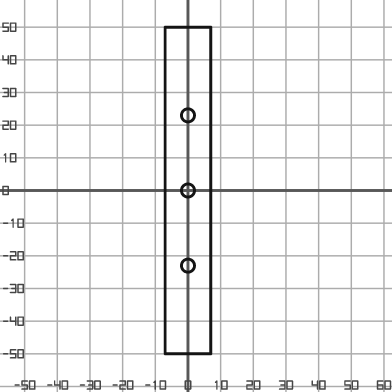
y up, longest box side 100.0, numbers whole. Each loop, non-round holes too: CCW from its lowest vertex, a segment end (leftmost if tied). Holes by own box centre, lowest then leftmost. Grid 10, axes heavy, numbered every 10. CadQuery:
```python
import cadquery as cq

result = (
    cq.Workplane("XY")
    .moveTo(-7.0, -50.0)
    .lineTo(7.0, -50.0)
    .lineTo(7.0, 50.0)
    .lineTo(-7.0, 50.0)
    .close()
    .moveTo(0.0, -23.0)
    .circle(2.0)
    .moveTo(0.0, 0.0)
    .circle(2.0)
    .moveTo(0.0, 23.0)
    .circle(2.0)
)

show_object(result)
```